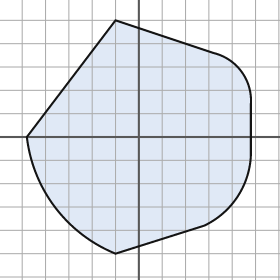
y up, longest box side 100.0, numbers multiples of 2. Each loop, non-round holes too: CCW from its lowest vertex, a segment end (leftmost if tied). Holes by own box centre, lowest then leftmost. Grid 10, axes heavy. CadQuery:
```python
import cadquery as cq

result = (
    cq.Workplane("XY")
    .moveTo(-10.0, -50.0)
    .lineTo(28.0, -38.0)
    .threePointArc((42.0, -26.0), (48.0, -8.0))
    .lineTo(48.0, 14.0)
    .threePointArc((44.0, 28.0), (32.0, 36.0))
    .lineTo(-10.0, 50.0)
    .lineTo(-48.0, 0.0)
    .threePointArc((-36.0, -30.0), (-10.0, -50.0))
    .close()
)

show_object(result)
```